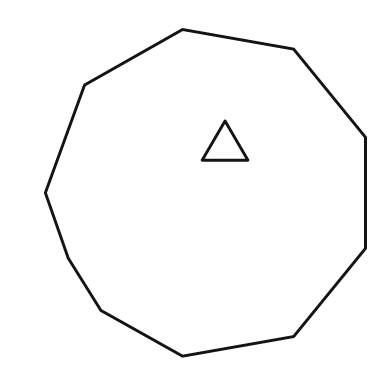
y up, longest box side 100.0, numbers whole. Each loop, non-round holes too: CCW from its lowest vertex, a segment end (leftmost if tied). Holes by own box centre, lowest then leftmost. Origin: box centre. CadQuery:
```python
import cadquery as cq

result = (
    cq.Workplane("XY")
    .moveTo(-7.0, -50.0)
    .lineTo(27.0, -44.0)
    .lineTo(49.0, -17.0)
    .lineTo(49.0, 17.0)
    .lineTo(27.0, 44.0)
    .lineTo(-7.0, 50.0)
    .lineTo(-37.0, 33.0)
    .lineTo(-49.0, 0.0)
    .lineTo(-42.0, -20.0)
    .lineTo(-32.0, -36.0)
    .close()
    .moveTo(-1.0, 10.0)
    .lineTo(13.0, 10.0)
    .lineTo(6.0, 22.0)
    .close()
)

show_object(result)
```